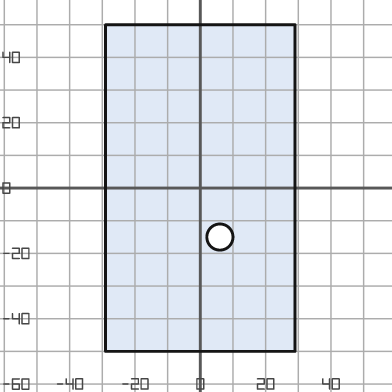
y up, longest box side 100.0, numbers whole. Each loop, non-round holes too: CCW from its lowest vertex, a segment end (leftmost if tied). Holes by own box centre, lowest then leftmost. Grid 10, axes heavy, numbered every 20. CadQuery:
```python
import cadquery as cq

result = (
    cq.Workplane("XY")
    .moveTo(-29.0, -50.0)
    .lineTo(29.0, -50.0)
    .lineTo(29.0, 50.0)
    .lineTo(-29.0, 50.0)
    .close()
    .moveTo(6.0, -15.0)
    .circle(4.0)
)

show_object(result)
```